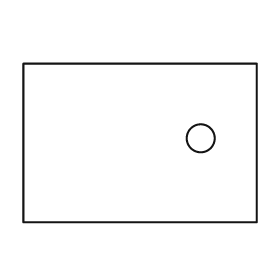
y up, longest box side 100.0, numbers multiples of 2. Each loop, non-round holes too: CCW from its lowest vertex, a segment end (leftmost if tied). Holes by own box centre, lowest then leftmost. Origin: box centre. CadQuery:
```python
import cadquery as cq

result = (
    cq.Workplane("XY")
    .moveTo(-50.0, -34.0)
    .lineTo(50.0, -34.0)
    .lineTo(50.0, 34.0)
    .lineTo(-50.0, 34.0)
    .close()
    .moveTo(26.0, 2.0)
    .circle(6.0)
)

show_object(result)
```